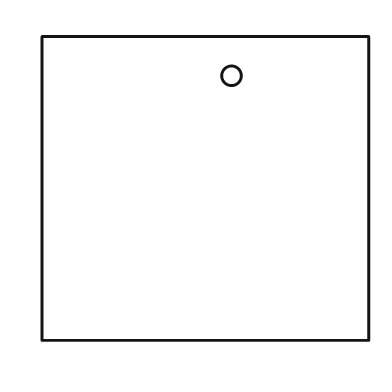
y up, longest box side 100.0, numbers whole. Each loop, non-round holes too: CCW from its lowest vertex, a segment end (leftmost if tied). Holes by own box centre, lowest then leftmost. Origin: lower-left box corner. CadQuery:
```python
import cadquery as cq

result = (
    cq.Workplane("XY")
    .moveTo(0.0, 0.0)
    .lineTo(100.0, 0.0)
    .lineTo(100.0, 93.0)
    .lineTo(0.0, 93.0)
    .close()
    .moveTo(58.0, 81.0)
    .circle(3.0)
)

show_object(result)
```